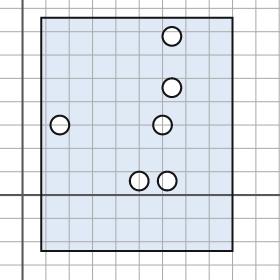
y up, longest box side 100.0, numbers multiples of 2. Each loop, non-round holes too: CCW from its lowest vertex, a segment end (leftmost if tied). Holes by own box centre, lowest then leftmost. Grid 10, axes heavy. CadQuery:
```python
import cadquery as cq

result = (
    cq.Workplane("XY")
    .moveTo(8.0, -24.0)
    .lineTo(90.0, -24.0)
    .lineTo(90.0, 76.0)
    .lineTo(8.0, 76.0)
    .close()
    .moveTo(50.0, 6.0)
    .circle(4.0)
    .moveTo(62.0, 6.0)
    .circle(4.0)
    .moveTo(16.0, 30.0)
    .circle(4.0)
    .moveTo(60.0, 30.0)
    .circle(4.0)
    .moveTo(64.0, 46.0)
    .circle(4.0)
    .moveTo(64.0, 68.0)
    .circle(4.0)
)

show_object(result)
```